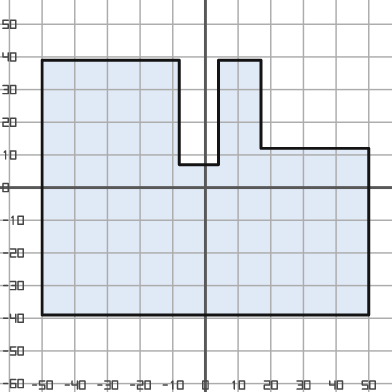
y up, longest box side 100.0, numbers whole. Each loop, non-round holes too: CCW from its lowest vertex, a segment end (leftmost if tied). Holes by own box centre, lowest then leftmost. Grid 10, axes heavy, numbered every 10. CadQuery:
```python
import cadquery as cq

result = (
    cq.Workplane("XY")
    .moveTo(-50.0, -39.0)
    .lineTo(50.0, -39.0)
    .lineTo(50.0, 12.0)
    .lineTo(17.0, 12.0)
    .lineTo(17.0, 39.0)
    .lineTo(4.0, 39.0)
    .lineTo(4.0, 7.0)
    .lineTo(-8.0, 7.0)
    .lineTo(-8.0, 39.0)
    .lineTo(-50.0, 39.0)
    .close()
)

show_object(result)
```